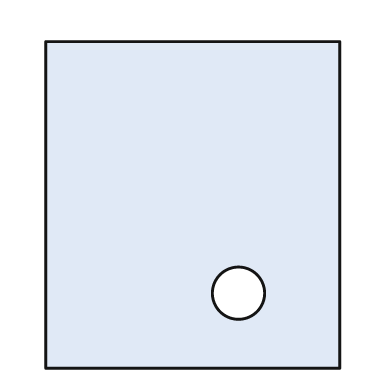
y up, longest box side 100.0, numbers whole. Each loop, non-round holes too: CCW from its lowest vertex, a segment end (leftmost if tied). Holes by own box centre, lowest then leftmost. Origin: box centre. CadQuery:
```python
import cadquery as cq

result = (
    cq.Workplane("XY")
    .moveTo(-45.0, -50.0)
    .lineTo(45.0, -50.0)
    .lineTo(45.0, 50.0)
    .lineTo(-45.0, 50.0)
    .close()
    .moveTo(14.0, -27.0)
    .circle(8.0)
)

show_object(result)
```